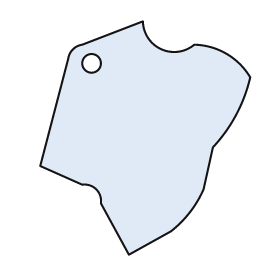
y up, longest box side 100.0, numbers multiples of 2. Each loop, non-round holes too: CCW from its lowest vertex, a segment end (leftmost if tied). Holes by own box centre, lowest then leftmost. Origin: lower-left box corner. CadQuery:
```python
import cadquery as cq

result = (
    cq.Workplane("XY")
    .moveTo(38.0, 0.0)
    .lineTo(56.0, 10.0)
    .threePointArc((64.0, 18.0), (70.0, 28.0))
    .lineTo(74.0, 46.0)
    .threePointArc((84.0, 60.0), (90.0, 76.0))
    .threePointArc((80.0, 86.0), (66.0, 90.0))
    .threePointArc((52.0, 88.0), (44.0, 100.0))
    .lineTo(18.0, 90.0)
    .threePointArc((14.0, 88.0), (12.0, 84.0))
    .lineTo(0.0, 38.0)
    .lineTo(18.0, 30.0)
    .threePointArc((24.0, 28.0), (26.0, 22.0))
    .close()
    .moveTo(22.0, 82.0)
    .circle(4.0)
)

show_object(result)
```